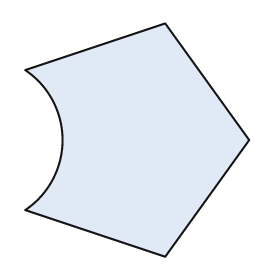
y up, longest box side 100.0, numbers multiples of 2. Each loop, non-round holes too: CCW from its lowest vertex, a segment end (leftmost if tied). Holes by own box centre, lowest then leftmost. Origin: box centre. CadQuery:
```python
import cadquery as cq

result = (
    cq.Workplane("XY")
    .moveTo(12.0, -50.0)
    .lineTo(48.0, 0.0)
    .lineTo(12.0, 50.0)
    .lineTo(-48.0, 30.0)
    .threePointArc((-32.0, 0.0), (-48.0, -30.0))
    .close()
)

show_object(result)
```